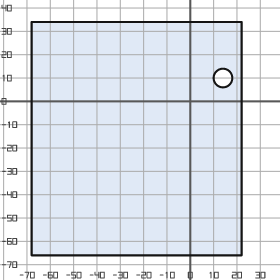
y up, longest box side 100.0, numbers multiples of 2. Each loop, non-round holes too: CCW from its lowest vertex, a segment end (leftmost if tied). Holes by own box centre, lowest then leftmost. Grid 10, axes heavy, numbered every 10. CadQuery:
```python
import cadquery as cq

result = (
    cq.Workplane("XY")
    .moveTo(-68.0, -66.0)
    .lineTo(22.0, -66.0)
    .lineTo(22.0, 34.0)
    .lineTo(-68.0, 34.0)
    .close()
    .moveTo(14.0, 10.0)
    .circle(4.0)
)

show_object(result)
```